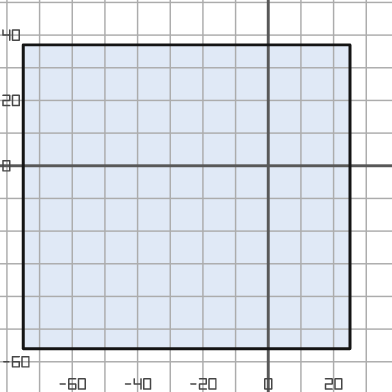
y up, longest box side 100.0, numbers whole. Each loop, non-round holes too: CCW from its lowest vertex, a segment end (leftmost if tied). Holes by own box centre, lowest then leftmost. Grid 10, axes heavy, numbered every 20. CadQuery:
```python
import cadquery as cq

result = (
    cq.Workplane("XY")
    .moveTo(-75.0, -56.0)
    .lineTo(25.0, -56.0)
    .lineTo(25.0, 37.0)
    .lineTo(-75.0, 37.0)
    .close()
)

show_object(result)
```